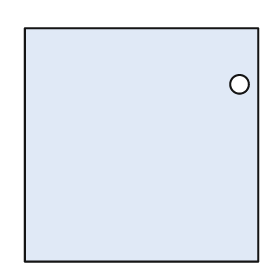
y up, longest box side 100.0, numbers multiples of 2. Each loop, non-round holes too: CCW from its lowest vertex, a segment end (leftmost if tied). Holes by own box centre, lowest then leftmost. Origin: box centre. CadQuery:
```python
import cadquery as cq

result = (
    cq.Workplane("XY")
    .moveTo(-50.0, -50.0)
    .lineTo(50.0, -50.0)
    .lineTo(50.0, 50.0)
    .lineTo(-50.0, 50.0)
    .close()
    .moveTo(42.0, 26.0)
    .circle(4.0)
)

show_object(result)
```